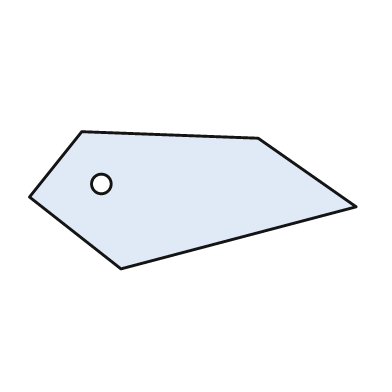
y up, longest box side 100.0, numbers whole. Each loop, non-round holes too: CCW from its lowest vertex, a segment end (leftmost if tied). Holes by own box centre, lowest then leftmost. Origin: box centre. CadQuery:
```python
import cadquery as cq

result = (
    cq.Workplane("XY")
    .moveTo(-22.0, -21.0)
    .lineTo(50.0, -2.0)
    .lineTo(20.0, 19.0)
    .lineTo(-34.0, 21.0)
    .lineTo(-50.0, 1.0)
    .close()
    .moveTo(-28.0, 5.0)
    .circle(3.0)
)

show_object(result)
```